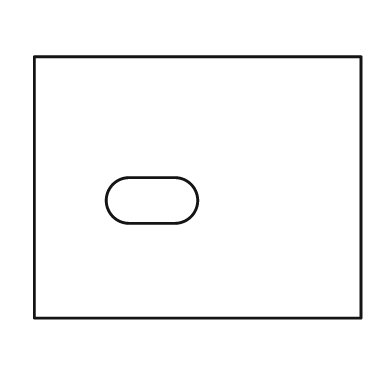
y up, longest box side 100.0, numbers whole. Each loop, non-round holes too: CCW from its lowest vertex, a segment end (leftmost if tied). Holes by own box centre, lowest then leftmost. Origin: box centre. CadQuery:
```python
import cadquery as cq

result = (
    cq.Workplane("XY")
    .moveTo(-50.0, -40.0)
    .lineTo(50.0, -40.0)
    .lineTo(50.0, 40.0)
    .lineTo(-50.0, 40.0)
    .close()
    .moveTo(-21.0, -11.0)
    .lineTo(-7.0, -11.0)
    .threePointArc((0.0, -4.0), (-7.0, 3.0))
    .lineTo(-21.0, 3.0)
    .threePointArc((-28.0, -4.0), (-21.0, -11.0))
    .close()
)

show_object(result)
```